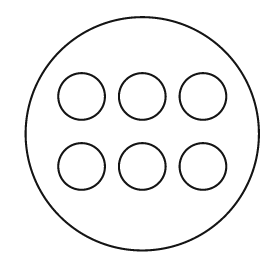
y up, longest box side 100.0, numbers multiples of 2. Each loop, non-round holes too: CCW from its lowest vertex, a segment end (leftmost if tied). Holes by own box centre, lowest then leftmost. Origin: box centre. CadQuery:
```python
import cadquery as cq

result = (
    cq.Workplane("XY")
    .moveTo(0.0, 0.0)
    .circle(50.0)
    .moveTo(-26.0, -14.0)
    .circle(10.0)
    .moveTo(0.0, -14.0)
    .circle(10.0)
    .moveTo(26.0, -14.0)
    .circle(10.0)
    .moveTo(-26.0, 16.0)
    .circle(10.0)
    .moveTo(0.0, 16.0)
    .circle(10.0)
    .moveTo(26.0, 16.0)
    .circle(10.0)
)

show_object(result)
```